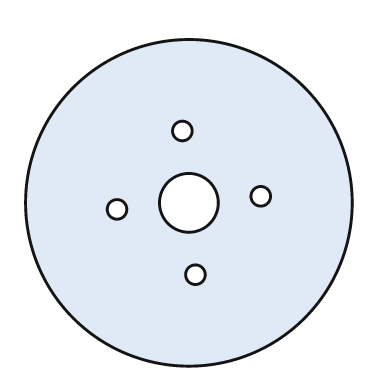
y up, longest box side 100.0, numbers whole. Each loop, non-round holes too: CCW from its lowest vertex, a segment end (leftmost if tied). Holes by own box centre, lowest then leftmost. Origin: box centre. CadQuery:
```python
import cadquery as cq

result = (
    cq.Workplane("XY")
    .moveTo(0.0, 0.0)
    .circle(50.0)
    .moveTo(2.0, -22.0)
    .circle(3.0)
    .moveTo(-22.0, -2.0)
    .circle(3.0)
    .moveTo(0.0, 0.0)
    .circle(9.0)
    .moveTo(22.0, 2.0)
    .circle(3.0)
    .moveTo(-2.0, 22.0)
    .circle(3.0)
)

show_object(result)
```